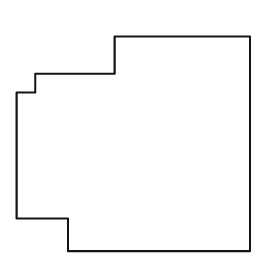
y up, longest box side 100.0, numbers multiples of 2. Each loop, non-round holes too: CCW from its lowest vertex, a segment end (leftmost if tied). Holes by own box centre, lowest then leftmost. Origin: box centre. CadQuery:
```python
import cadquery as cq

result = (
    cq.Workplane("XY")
    .moveTo(-28.0, -46.0)
    .lineTo(50.0, -46.0)
    .lineTo(50.0, 46.0)
    .lineTo(-8.0, 46.0)
    .lineTo(-8.0, 30.0)
    .lineTo(-42.0, 30.0)
    .lineTo(-42.0, 22.0)
    .lineTo(-50.0, 22.0)
    .lineTo(-50.0, -32.0)
    .lineTo(-28.0, -32.0)
    .close()
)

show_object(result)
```